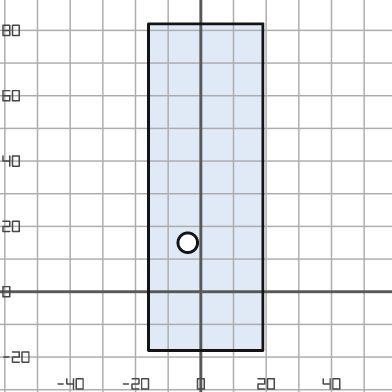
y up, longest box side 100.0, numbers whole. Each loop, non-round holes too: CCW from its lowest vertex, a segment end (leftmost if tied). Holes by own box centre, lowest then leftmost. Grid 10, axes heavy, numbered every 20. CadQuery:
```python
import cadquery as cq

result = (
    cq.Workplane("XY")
    .moveTo(-16.0, -18.0)
    .lineTo(19.0, -18.0)
    .lineTo(19.0, 82.0)
    .lineTo(-16.0, 82.0)
    .close()
    .moveTo(-4.0, 15.0)
    .circle(3.0)
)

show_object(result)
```